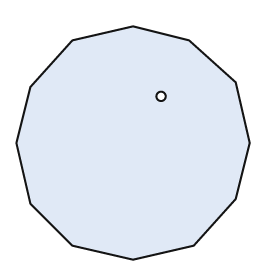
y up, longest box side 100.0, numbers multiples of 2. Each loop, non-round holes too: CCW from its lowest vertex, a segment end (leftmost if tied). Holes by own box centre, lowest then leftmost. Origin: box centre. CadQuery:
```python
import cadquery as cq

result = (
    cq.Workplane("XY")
    .moveTo(0.0, -50.0)
    .lineTo(26.0, -44.0)
    .lineTo(44.0, -24.0)
    .lineTo(50.0, 0.0)
    .lineTo(44.0, 26.0)
    .lineTo(24.0, 44.0)
    .lineTo(0.0, 50.0)
    .lineTo(-26.0, 44.0)
    .lineTo(-44.0, 24.0)
    .lineTo(-50.0, 0.0)
    .lineTo(-44.0, -26.0)
    .lineTo(-26.0, -44.0)
    .close()
    .moveTo(12.0, 20.0)
    .circle(2.0)
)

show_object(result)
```